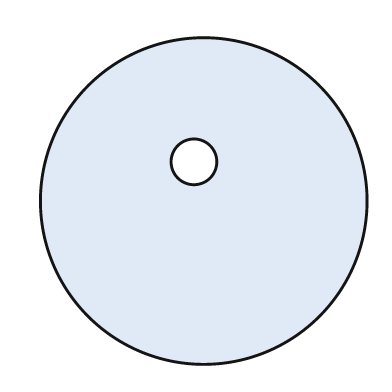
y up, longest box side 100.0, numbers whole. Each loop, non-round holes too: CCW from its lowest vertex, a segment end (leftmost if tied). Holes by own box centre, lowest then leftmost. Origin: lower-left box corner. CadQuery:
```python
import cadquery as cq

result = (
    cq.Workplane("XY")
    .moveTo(50.0, 50.0)
    .circle(50.0)
    .moveTo(47.0, 62.0)
    .circle(7.0)
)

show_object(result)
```